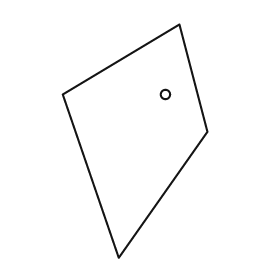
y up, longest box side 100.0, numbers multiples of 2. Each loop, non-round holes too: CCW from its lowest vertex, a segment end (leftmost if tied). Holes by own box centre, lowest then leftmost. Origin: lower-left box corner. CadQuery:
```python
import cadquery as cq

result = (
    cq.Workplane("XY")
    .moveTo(24.0, 0.0)
    .lineTo(62.0, 54.0)
    .lineTo(50.0, 100.0)
    .lineTo(0.0, 70.0)
    .close()
    .moveTo(44.0, 70.0)
    .circle(2.0)
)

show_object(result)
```